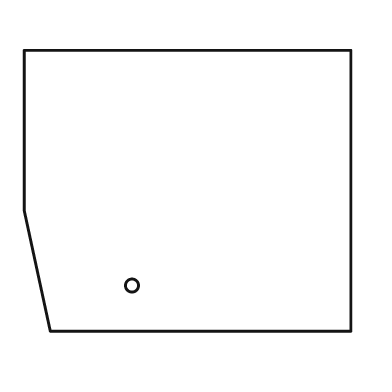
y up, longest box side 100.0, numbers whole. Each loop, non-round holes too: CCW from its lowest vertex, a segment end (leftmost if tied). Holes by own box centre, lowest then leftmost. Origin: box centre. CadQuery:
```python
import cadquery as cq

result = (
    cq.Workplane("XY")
    .moveTo(-42.0, -43.0)
    .lineTo(50.0, -43.0)
    .lineTo(50.0, 43.0)
    .lineTo(-50.0, 43.0)
    .lineTo(-50.0, -6.0)
    .close()
    .moveTo(-17.0, -29.0)
    .circle(2.0)
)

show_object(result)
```